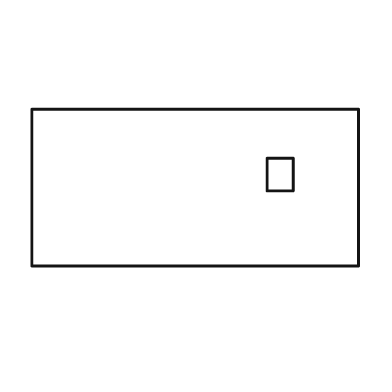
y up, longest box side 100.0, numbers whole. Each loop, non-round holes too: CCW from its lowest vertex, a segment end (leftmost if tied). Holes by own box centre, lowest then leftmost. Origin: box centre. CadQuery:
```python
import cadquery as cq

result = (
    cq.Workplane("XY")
    .moveTo(-50.0, -24.0)
    .lineTo(50.0, -24.0)
    .lineTo(50.0, 24.0)
    .lineTo(-50.0, 24.0)
    .close()
    .moveTo(22.0, -1.0)
    .lineTo(30.0, -1.0)
    .lineTo(30.0, 9.0)
    .lineTo(22.0, 9.0)
    .close()
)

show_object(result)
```